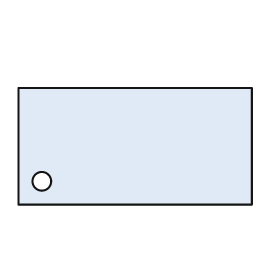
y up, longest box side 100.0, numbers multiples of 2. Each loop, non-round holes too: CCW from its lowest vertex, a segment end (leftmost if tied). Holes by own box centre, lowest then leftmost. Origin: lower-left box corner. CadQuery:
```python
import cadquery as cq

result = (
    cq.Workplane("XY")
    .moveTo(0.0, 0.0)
    .lineTo(100.0, 0.0)
    .lineTo(100.0, 50.0)
    .lineTo(0.0, 50.0)
    .close()
    .moveTo(10.0, 10.0)
    .circle(4.0)
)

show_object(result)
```